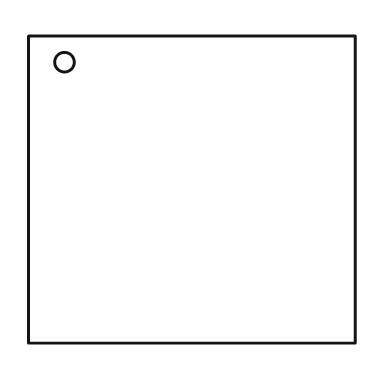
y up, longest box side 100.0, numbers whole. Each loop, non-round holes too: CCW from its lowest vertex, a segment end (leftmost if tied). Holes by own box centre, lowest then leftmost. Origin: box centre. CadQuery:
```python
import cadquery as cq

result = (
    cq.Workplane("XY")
    .moveTo(-50.0, -47.0)
    .lineTo(50.0, -47.0)
    .lineTo(50.0, 47.0)
    .lineTo(-50.0, 47.0)
    .close()
    .moveTo(-39.0, 39.0)
    .circle(3.0)
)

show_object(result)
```